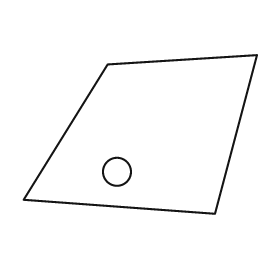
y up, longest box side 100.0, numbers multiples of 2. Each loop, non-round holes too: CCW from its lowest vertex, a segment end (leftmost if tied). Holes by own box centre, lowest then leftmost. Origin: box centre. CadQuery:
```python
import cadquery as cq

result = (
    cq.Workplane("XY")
    .moveTo(32.0, -34.0)
    .lineTo(50.0, 34.0)
    .lineTo(-14.0, 30.0)
    .lineTo(-50.0, -28.0)
    .close()
    .moveTo(-10.0, -16.0)
    .circle(6.0)
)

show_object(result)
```